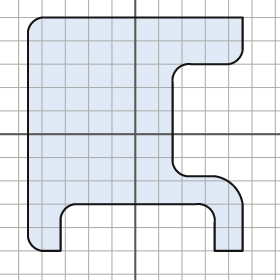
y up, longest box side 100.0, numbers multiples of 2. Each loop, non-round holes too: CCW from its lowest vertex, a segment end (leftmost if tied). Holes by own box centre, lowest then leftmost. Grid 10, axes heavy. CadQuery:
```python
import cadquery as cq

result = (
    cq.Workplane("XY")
    .moveTo(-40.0, -50.0)
    .lineTo(-32.0, -50.0)
    .lineTo(-32.0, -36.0)
    .threePointArc((-30.0, -32.0), (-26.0, -30.0))
    .lineTo(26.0, -30.0)
    .threePointArc((32.0, -32.0), (34.0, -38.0))
    .lineTo(34.0, -50.0)
    .lineTo(46.0, -50.0)
    .lineTo(46.0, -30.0)
    .threePointArc((42.0, -22.0), (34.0, -18.0))
    .lineTo(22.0, -18.0)
    .threePointArc((18.0, -16.0), (16.0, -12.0))
    .lineTo(16.0, 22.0)
    .threePointArc((18.0, 28.0), (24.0, 30.0))
    .lineTo(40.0, 30.0)
    .threePointArc((44.0, 32.0), (46.0, 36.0))
    .lineTo(46.0, 50.0)
    .lineTo(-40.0, 50.0)
    .threePointArc((-44.0, 48.0), (-46.0, 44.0))
    .lineTo(-46.0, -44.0)
    .threePointArc((-44.0, -48.0), (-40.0, -50.0))
    .close()
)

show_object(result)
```